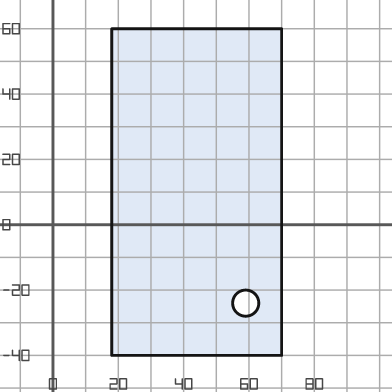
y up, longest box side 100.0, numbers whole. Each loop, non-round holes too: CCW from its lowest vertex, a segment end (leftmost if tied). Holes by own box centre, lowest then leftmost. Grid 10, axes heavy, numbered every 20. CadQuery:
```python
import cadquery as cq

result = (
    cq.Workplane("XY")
    .moveTo(18.0, -40.0)
    .lineTo(70.0, -40.0)
    .lineTo(70.0, 60.0)
    .lineTo(18.0, 60.0)
    .close()
    .moveTo(59.0, -24.0)
    .circle(4.0)
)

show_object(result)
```